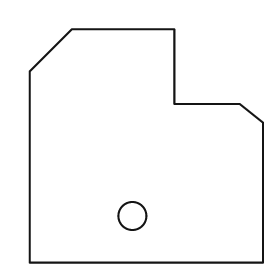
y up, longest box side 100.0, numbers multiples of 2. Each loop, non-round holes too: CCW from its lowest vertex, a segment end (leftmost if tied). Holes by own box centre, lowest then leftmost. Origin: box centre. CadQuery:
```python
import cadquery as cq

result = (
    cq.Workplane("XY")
    .moveTo(-50.0, -50.0)
    .lineTo(50.0, -50.0)
    .lineTo(50.0, 10.0)
    .lineTo(40.0, 18.0)
    .lineTo(12.0, 18.0)
    .lineTo(12.0, 50.0)
    .lineTo(-32.0, 50.0)
    .lineTo(-50.0, 32.0)
    .close()
    .moveTo(-6.0, -30.0)
    .circle(6.0)
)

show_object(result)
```